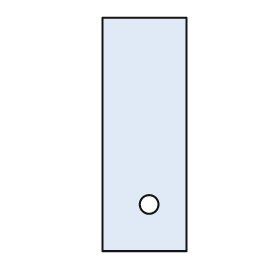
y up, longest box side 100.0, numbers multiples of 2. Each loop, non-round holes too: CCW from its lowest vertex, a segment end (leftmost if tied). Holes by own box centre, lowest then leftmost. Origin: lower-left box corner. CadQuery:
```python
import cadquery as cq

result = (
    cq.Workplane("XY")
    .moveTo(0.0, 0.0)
    .lineTo(36.0, 0.0)
    .lineTo(36.0, 100.0)
    .lineTo(0.0, 100.0)
    .close()
    .moveTo(20.0, 20.0)
    .circle(4.0)
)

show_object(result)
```